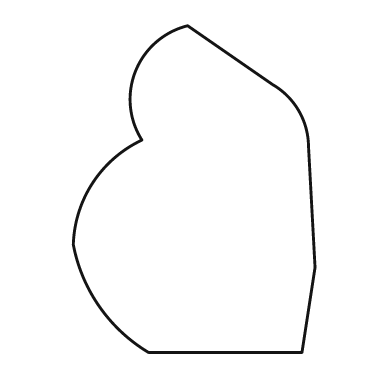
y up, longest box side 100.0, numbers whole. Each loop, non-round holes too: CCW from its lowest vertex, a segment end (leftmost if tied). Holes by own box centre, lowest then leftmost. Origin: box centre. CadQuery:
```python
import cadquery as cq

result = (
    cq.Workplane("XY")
    .moveTo(-14.0, -50.0)
    .lineTo(33.0, -50.0)
    .lineTo(37.0, -24.0)
    .lineTo(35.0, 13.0)
    .threePointArc((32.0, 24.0), (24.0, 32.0))
    .lineTo(-2.0, 50.0)
    .threePointArc((-18.0, 36.0), (-16.0, 15.0))
    .threePointArc((-31.0, 2.0), (-37.0, -17.0))
    .threePointArc((-29.0, -36.0), (-14.0, -50.0))
    .close()
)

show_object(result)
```